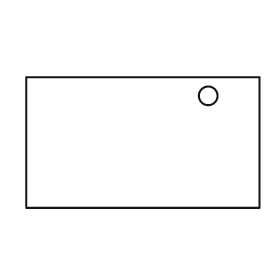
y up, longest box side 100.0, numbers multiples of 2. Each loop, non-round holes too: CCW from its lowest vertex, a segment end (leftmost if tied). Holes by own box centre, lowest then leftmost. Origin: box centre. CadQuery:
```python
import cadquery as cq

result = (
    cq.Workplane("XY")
    .moveTo(-50.0, -28.0)
    .lineTo(50.0, -28.0)
    .lineTo(50.0, 28.0)
    .lineTo(-50.0, 28.0)
    .close()
    .moveTo(28.0, 20.0)
    .circle(4.0)
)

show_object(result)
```